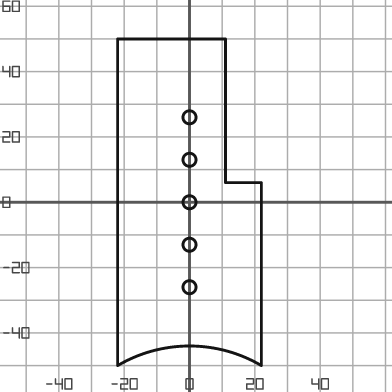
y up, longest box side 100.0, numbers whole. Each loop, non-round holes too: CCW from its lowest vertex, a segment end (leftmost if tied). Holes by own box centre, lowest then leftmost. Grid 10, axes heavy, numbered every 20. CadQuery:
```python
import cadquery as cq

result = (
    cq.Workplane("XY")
    .moveTo(-22.0, -50.0)
    .threePointArc((0.0, -44.0), (22.0, -50.0))
    .lineTo(22.0, 6.0)
    .lineTo(11.0, 6.0)
    .lineTo(11.0, 50.0)
    .lineTo(-22.0, 50.0)
    .close()
    .moveTo(0.0, -26.0)
    .circle(2.0)
    .moveTo(0.0, -13.0)
    .circle(2.0)
    .moveTo(0.0, 0.0)
    .circle(2.0)
    .moveTo(0.0, 13.0)
    .circle(2.0)
    .moveTo(0.0, 26.0)
    .circle(2.0)
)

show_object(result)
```